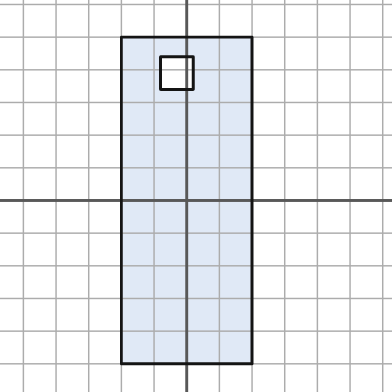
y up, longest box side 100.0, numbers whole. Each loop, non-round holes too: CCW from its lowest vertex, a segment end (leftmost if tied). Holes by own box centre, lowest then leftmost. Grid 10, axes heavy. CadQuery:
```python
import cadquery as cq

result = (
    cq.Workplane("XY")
    .moveTo(-20.0, -50.0)
    .lineTo(20.0, -50.0)
    .lineTo(20.0, 50.0)
    .lineTo(-20.0, 50.0)
    .close()
    .moveTo(-8.0, 34.0)
    .lineTo(2.0, 34.0)
    .lineTo(2.0, 44.0)
    .lineTo(-8.0, 44.0)
    .close()
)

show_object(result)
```